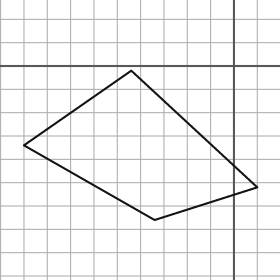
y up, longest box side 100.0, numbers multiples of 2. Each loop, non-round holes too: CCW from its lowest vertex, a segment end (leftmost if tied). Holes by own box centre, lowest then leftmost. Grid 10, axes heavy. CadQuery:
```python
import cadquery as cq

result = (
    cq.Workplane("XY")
    .moveTo(-34.0, -66.0)
    .lineTo(10.0, -52.0)
    .lineTo(-44.0, -2.0)
    .lineTo(-90.0, -34.0)
    .close()
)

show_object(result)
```